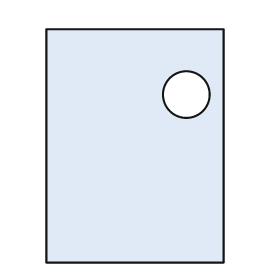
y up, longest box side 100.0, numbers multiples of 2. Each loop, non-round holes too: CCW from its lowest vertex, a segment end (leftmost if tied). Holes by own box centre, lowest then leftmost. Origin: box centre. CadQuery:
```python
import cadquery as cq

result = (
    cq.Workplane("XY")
    .moveTo(-38.0, -50.0)
    .lineTo(38.0, -50.0)
    .lineTo(38.0, 50.0)
    .lineTo(-38.0, 50.0)
    .close()
    .moveTo(22.0, 22.0)
    .circle(10.0)
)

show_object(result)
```